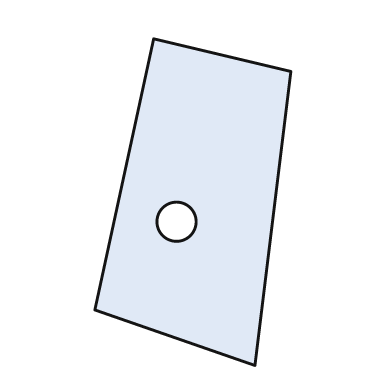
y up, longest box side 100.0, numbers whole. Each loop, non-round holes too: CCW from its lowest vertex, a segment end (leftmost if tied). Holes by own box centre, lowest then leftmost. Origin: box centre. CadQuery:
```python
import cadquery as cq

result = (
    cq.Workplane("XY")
    .moveTo(19.0, -50.0)
    .lineTo(30.0, 40.0)
    .lineTo(-12.0, 50.0)
    .lineTo(-30.0, -33.0)
    .close()
    .moveTo(-5.0, -6.0)
    .circle(6.0)
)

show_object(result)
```